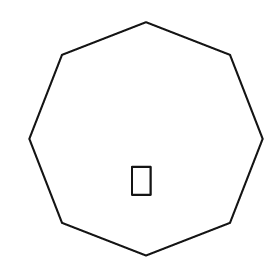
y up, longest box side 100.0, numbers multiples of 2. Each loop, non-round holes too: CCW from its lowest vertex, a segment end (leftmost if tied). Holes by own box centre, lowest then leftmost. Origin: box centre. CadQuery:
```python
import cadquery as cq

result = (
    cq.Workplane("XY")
    .moveTo(0.0, -50.0)
    .lineTo(36.0, -36.0)
    .lineTo(50.0, 0.0)
    .lineTo(36.0, 36.0)
    .lineTo(0.0, 50.0)
    .lineTo(-36.0, 36.0)
    .lineTo(-50.0, 0.0)
    .lineTo(-36.0, -36.0)
    .close()
    .moveTo(-6.0, -24.0)
    .lineTo(2.0, -24.0)
    .lineTo(2.0, -12.0)
    .lineTo(-6.0, -12.0)
    .close()
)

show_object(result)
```